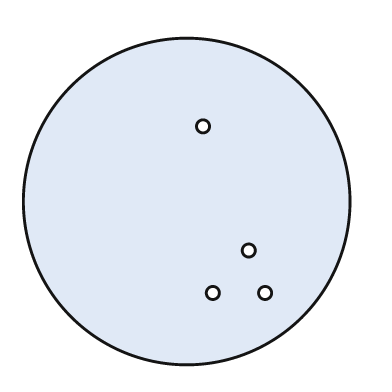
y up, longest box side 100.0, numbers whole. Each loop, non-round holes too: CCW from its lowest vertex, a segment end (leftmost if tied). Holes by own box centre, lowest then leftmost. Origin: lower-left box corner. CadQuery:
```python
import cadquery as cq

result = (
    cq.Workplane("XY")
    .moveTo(50.0, 50.0)
    .circle(50.0)
    .moveTo(58.0, 22.0)
    .circle(2.0)
    .moveTo(74.0, 22.0)
    .circle(2.0)
    .moveTo(69.0, 35.0)
    .circle(2.0)
    .moveTo(55.0, 73.0)
    .circle(2.0)
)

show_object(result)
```